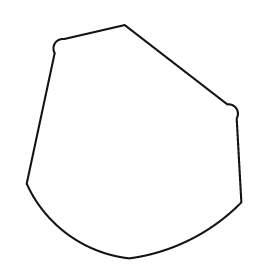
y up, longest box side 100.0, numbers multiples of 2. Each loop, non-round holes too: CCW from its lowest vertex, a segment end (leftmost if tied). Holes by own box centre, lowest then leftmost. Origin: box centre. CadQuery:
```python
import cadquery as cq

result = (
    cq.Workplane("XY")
    .moveTo(-2.0, -50.0)
    .threePointArc((24.0, -42.0), (46.0, -26.0))
    .lineTo(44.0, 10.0)
    .threePointArc((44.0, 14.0), (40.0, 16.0))
    .lineTo(-4.0, 50.0)
    .lineTo(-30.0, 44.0)
    .threePointArc((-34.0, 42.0), (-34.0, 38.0))
    .lineTo(-46.0, -18.0)
    .threePointArc((-28.0, -40.0), (-2.0, -50.0))
    .close()
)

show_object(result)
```